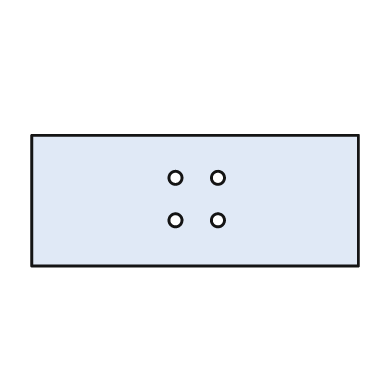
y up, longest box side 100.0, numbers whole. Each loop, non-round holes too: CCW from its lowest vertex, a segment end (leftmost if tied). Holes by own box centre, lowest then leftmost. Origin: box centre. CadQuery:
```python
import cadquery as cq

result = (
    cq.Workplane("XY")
    .moveTo(-50.0, -20.0)
    .lineTo(50.0, -20.0)
    .lineTo(50.0, 20.0)
    .lineTo(-50.0, 20.0)
    .close()
    .moveTo(-6.0, -6.0)
    .circle(2.0)
    .moveTo(7.0, -6.0)
    .circle(2.0)
    .moveTo(-6.0, 7.0)
    .circle(2.0)
    .moveTo(7.0, 7.0)
    .circle(2.0)
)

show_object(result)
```